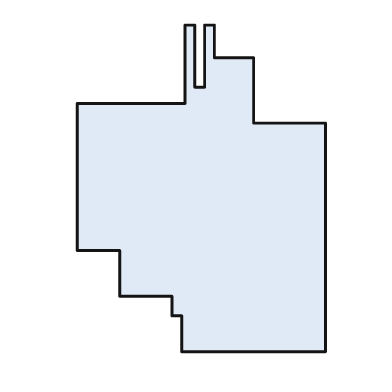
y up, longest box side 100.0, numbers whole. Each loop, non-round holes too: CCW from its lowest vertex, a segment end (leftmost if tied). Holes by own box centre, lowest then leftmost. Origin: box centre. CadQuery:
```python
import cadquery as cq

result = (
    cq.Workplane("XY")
    .moveTo(-6.0, -50.0)
    .lineTo(38.0, -50.0)
    .lineTo(38.0, 20.0)
    .lineTo(16.0, 20.0)
    .lineTo(16.0, 40.0)
    .lineTo(4.0, 40.0)
    .lineTo(4.0, 50.0)
    .lineTo(1.0, 50.0)
    .lineTo(1.0, 31.0)
    .lineTo(-2.0, 31.0)
    .lineTo(-2.0, 50.0)
    .lineTo(-5.0, 50.0)
    .lineTo(-5.0, 26.0)
    .lineTo(-38.0, 26.0)
    .lineTo(-38.0, -19.0)
    .lineTo(-25.0, -19.0)
    .lineTo(-25.0, -33.0)
    .lineTo(-9.0, -33.0)
    .lineTo(-9.0, -39.0)
    .lineTo(-6.0, -39.0)
    .close()
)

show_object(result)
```